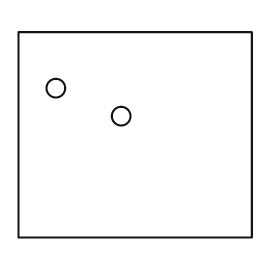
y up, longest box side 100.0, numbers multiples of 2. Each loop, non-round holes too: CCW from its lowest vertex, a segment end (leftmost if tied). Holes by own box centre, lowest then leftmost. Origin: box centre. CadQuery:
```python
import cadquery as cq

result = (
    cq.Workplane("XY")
    .moveTo(-50.0, -44.0)
    .lineTo(50.0, -44.0)
    .lineTo(50.0, 44.0)
    .lineTo(-50.0, 44.0)
    .close()
    .moveTo(-6.0, 8.0)
    .circle(4.0)
    .moveTo(-34.0, 20.0)
    .circle(4.0)
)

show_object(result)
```